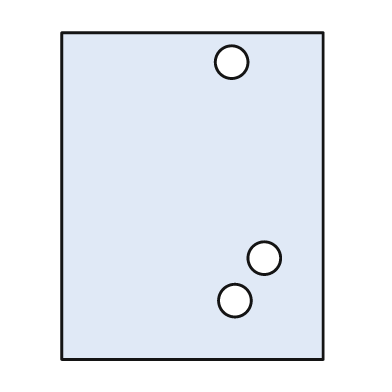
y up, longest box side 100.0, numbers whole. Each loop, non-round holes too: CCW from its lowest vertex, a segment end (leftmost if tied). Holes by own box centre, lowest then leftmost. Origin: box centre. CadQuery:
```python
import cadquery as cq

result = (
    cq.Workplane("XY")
    .moveTo(-40.0, -50.0)
    .lineTo(40.0, -50.0)
    .lineTo(40.0, 50.0)
    .lineTo(-40.0, 50.0)
    .close()
    .moveTo(13.0, -32.0)
    .circle(5.0)
    .moveTo(22.0, -19.0)
    .circle(5.0)
    .moveTo(12.0, 41.0)
    .circle(5.0)
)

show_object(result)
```